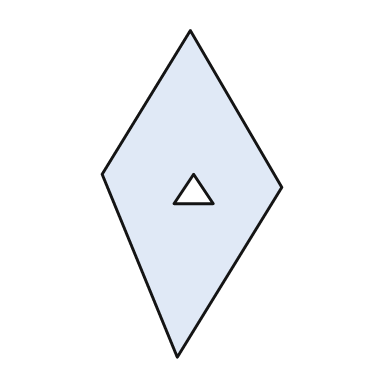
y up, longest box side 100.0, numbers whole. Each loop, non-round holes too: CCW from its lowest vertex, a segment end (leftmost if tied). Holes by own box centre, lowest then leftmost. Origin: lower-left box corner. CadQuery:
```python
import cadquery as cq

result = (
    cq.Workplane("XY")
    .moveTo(23.0, 0.0)
    .lineTo(55.0, 52.0)
    .lineTo(27.0, 100.0)
    .lineTo(0.0, 56.0)
    .close()
    .moveTo(22.0, 47.0)
    .lineTo(34.0, 47.0)
    .lineTo(28.0, 56.0)
    .close()
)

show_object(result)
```